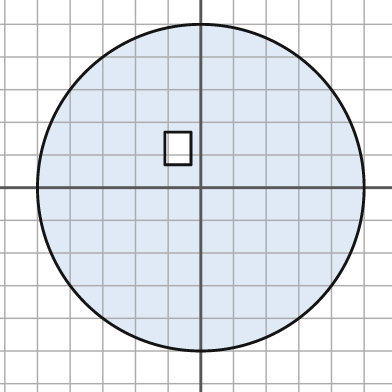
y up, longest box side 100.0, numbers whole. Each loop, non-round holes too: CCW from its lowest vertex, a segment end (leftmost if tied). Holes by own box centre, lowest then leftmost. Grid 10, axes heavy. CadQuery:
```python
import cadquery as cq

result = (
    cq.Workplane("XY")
    .moveTo(0.0, 0.0)
    .circle(50.0)
    .moveTo(-11.0, 7.0)
    .lineTo(-3.0, 7.0)
    .lineTo(-3.0, 17.0)
    .lineTo(-11.0, 17.0)
    .close()
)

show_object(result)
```